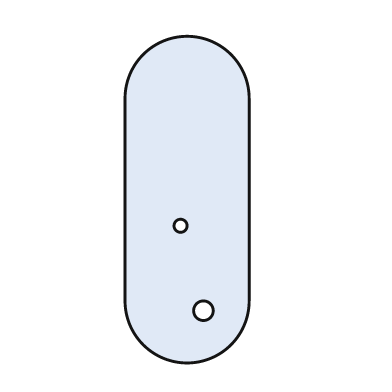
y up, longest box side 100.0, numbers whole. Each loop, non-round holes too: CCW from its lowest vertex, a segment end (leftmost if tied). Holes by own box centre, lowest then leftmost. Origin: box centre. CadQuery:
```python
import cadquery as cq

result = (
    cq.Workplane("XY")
    .moveTo(-19.0, -31.0)
    .threePointArc((0.0, -50.0), (19.0, -31.0))
    .lineTo(19.0, 31.0)
    .threePointArc((0.0, 50.0), (-19.0, 31.0))
    .close()
    .moveTo(5.0, -34.0)
    .circle(3.0)
    .moveTo(-2.0, -8.0)
    .circle(2.0)
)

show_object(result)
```